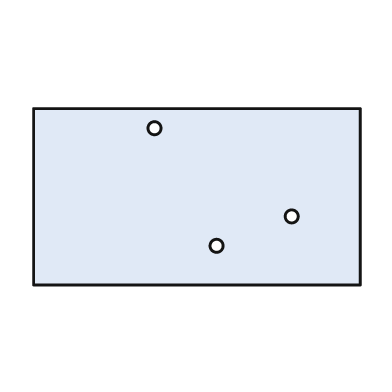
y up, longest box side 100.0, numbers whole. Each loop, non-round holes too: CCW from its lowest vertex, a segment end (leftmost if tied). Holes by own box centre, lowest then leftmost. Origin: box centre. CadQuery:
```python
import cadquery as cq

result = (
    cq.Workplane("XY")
    .moveTo(-50.0, -27.0)
    .lineTo(50.0, -27.0)
    .lineTo(50.0, 27.0)
    .lineTo(-50.0, 27.0)
    .close()
    .moveTo(6.0, -15.0)
    .circle(2.0)
    .moveTo(29.0, -6.0)
    .circle(2.0)
    .moveTo(-13.0, 21.0)
    .circle(2.0)
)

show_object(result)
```